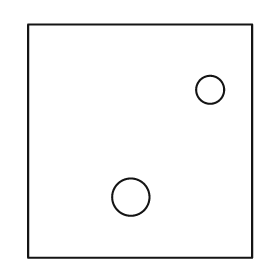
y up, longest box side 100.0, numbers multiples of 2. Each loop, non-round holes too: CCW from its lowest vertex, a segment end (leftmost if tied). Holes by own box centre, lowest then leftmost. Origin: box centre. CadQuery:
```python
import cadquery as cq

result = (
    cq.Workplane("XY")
    .moveTo(-48.0, -50.0)
    .lineTo(48.0, -50.0)
    .lineTo(48.0, 50.0)
    .lineTo(-48.0, 50.0)
    .close()
    .moveTo(-4.0, -24.0)
    .circle(8.0)
    .moveTo(30.0, 22.0)
    .circle(6.0)
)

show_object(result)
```